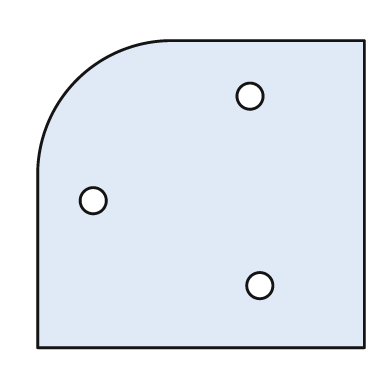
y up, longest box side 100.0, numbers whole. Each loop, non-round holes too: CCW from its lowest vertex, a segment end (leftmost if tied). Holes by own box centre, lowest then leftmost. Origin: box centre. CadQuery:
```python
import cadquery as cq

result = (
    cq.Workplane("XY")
    .moveTo(-50.0, -47.0)
    .lineTo(50.0, -47.0)
    .lineTo(50.0, 47.0)
    .lineTo(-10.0, 47.0)
    .threePointArc((-38.0, 35.0), (-50.0, 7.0))
    .close()
    .moveTo(18.0, -28.0)
    .circle(4.0)
    .moveTo(-33.0, -2.0)
    .circle(4.0)
    .moveTo(15.0, 30.0)
    .circle(4.0)
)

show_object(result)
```